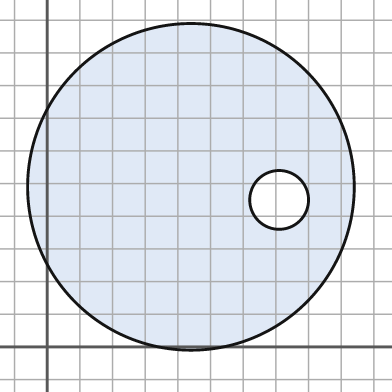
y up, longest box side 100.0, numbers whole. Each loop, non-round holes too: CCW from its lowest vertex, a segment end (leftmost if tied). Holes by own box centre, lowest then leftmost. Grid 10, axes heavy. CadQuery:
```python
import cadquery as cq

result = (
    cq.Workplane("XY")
    .moveTo(44.0, 49.0)
    .circle(50.0)
    .moveTo(71.0, 45.0)
    .circle(9.0)
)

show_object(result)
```